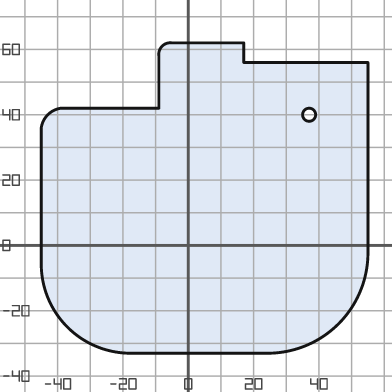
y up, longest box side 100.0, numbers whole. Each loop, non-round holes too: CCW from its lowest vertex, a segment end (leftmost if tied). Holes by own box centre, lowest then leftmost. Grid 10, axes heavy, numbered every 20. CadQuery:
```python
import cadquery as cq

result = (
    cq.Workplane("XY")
    .moveTo(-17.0, -33.0)
    .lineTo(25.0, -33.0)
    .threePointArc((46.0, -24.0), (55.0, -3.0))
    .lineTo(55.0, 56.0)
    .lineTo(17.0, 56.0)
    .lineTo(17.0, 62.0)
    .lineTo(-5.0, 62.0)
    .threePointArc((-8.0, 61.0), (-9.0, 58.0))
    .lineTo(-9.0, 42.0)
    .lineTo(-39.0, 42.0)
    .threePointArc((-43.0, 40.0), (-45.0, 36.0))
    .lineTo(-45.0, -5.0)
    .threePointArc((-37.0, -25.0), (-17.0, -33.0))
    .close()
    .moveTo(37.0, 40.0)
    .circle(2.0)
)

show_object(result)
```